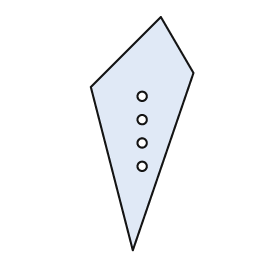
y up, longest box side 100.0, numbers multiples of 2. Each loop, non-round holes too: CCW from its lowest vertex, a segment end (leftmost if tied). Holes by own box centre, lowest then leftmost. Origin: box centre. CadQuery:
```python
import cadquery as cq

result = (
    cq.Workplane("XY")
    .moveTo(-4.0, -50.0)
    .lineTo(22.0, 26.0)
    .lineTo(8.0, 50.0)
    .lineTo(-22.0, 20.0)
    .close()
    .moveTo(0.0, -14.0)
    .circle(2.0)
    .moveTo(0.0, -4.0)
    .circle(2.0)
    .moveTo(0.0, 6.0)
    .circle(2.0)
    .moveTo(0.0, 16.0)
    .circle(2.0)
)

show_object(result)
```